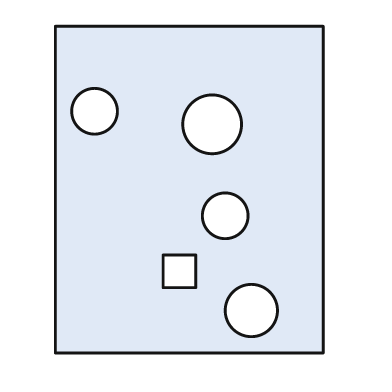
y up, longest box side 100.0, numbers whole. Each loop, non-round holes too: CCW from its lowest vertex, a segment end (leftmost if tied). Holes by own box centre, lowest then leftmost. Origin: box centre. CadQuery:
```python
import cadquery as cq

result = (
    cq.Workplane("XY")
    .moveTo(-41.0, -50.0)
    .lineTo(41.0, -50.0)
    .lineTo(41.0, 50.0)
    .lineTo(-41.0, 50.0)
    .close()
    .moveTo(19.0, -37.0)
    .circle(8.0)
    .moveTo(-8.0, -30.0)
    .lineTo(2.0, -30.0)
    .lineTo(2.0, -20.0)
    .lineTo(-8.0, -20.0)
    .close()
    .moveTo(11.0, -8.0)
    .circle(7.0)
    .moveTo(7.0, 20.0)
    .circle(9.0)
    .moveTo(-29.0, 24.0)
    .circle(7.0)
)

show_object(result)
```